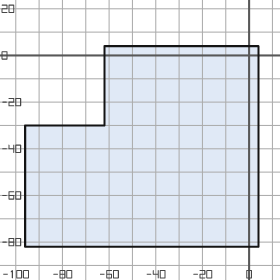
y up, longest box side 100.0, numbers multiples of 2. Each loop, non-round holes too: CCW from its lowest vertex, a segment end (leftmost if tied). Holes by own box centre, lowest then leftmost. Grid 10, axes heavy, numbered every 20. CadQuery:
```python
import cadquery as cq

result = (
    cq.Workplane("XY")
    .moveTo(-96.0, -82.0)
    .lineTo(4.0, -82.0)
    .lineTo(4.0, 4.0)
    .lineTo(-62.0, 4.0)
    .lineTo(-62.0, -30.0)
    .lineTo(-96.0, -30.0)
    .close()
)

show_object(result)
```